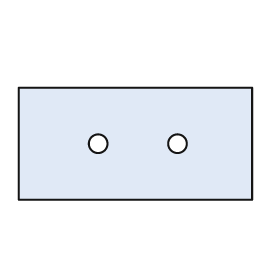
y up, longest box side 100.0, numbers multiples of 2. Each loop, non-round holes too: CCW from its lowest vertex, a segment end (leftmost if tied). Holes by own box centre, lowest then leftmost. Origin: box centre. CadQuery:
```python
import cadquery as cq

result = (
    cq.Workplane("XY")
    .moveTo(-50.0, -24.0)
    .lineTo(50.0, -24.0)
    .lineTo(50.0, 24.0)
    .lineTo(-50.0, 24.0)
    .close()
    .moveTo(-16.0, 0.0)
    .circle(4.0)
    .moveTo(18.0, 0.0)
    .circle(4.0)
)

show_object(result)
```